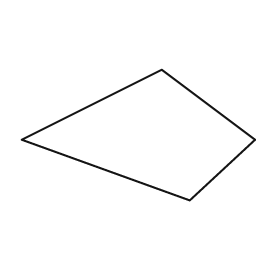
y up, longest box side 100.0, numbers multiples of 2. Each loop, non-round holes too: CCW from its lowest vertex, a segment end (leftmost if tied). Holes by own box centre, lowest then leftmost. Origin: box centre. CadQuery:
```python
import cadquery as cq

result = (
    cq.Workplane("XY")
    .moveTo(22.0, -28.0)
    .lineTo(50.0, -2.0)
    .lineTo(10.0, 28.0)
    .lineTo(-50.0, -2.0)
    .close()
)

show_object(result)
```